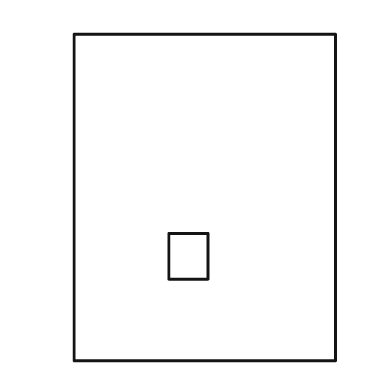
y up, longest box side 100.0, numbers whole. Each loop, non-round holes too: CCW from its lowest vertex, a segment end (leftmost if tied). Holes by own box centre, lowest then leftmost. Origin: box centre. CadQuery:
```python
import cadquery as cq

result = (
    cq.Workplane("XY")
    .moveTo(-40.0, -50.0)
    .lineTo(40.0, -50.0)
    .lineTo(40.0, 50.0)
    .lineTo(-40.0, 50.0)
    .close()
    .moveTo(-11.0, -25.0)
    .lineTo(1.0, -25.0)
    .lineTo(1.0, -11.0)
    .lineTo(-11.0, -11.0)
    .close()
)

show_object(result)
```